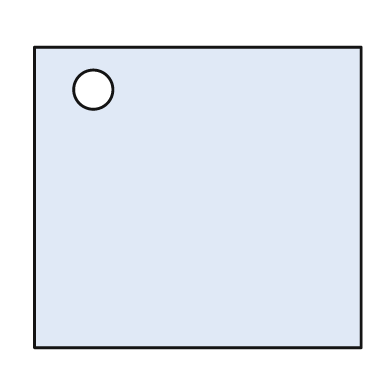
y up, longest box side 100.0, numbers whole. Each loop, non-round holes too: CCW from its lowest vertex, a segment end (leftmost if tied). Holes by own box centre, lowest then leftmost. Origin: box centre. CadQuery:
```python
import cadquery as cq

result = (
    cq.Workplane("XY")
    .moveTo(-50.0, -46.0)
    .lineTo(50.0, -46.0)
    .lineTo(50.0, 46.0)
    .lineTo(-50.0, 46.0)
    .close()
    .moveTo(-32.0, 33.0)
    .circle(6.0)
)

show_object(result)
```